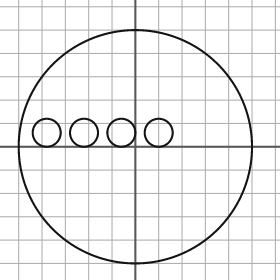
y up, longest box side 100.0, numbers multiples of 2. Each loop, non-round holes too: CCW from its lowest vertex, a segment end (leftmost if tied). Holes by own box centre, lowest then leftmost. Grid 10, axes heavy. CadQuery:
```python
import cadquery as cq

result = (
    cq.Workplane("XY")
    .moveTo(0.0, 0.0)
    .circle(50.0)
    .moveTo(-38.0, 6.0)
    .circle(6.0)
    .moveTo(-22.0, 6.0)
    .circle(6.0)
    .moveTo(-6.0, 6.0)
    .circle(6.0)
    .moveTo(10.0, 6.0)
    .circle(6.0)
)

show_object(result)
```